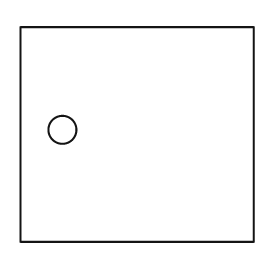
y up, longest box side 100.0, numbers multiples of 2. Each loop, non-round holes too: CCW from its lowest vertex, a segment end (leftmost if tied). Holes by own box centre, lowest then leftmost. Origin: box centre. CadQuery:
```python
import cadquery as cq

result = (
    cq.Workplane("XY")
    .moveTo(-50.0, -46.0)
    .lineTo(50.0, -46.0)
    .lineTo(50.0, 46.0)
    .lineTo(-50.0, 46.0)
    .close()
    .moveTo(-32.0, 2.0)
    .circle(6.0)
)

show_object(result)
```